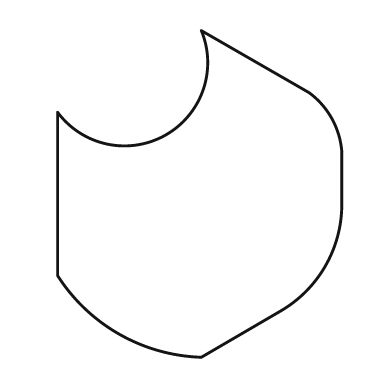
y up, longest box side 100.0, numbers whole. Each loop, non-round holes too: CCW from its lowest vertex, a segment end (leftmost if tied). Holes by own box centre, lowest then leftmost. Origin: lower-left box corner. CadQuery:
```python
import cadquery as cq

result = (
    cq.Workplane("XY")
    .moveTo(44.0, 0.0)
    .lineTo(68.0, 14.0)
    .threePointArc((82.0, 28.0), (87.0, 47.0))
    .lineTo(87.0, 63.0)
    .threePointArc((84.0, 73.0), (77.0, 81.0))
    .lineTo(44.0, 100.0)
    .threePointArc((33.0, 68.0), (0.0, 75.0))
    .lineTo(0.0, 25.0)
    .threePointArc((19.0, 7.0), (44.0, 0.0))
    .close()
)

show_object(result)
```